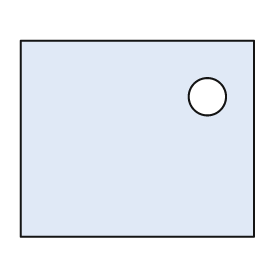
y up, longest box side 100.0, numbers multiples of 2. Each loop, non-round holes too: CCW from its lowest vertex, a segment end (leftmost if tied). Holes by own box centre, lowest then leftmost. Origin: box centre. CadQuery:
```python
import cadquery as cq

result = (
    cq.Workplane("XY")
    .moveTo(-50.0, -42.0)
    .lineTo(50.0, -42.0)
    .lineTo(50.0, 42.0)
    .lineTo(-50.0, 42.0)
    .close()
    .moveTo(30.0, 18.0)
    .circle(8.0)
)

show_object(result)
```